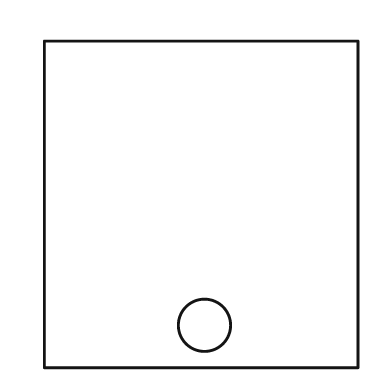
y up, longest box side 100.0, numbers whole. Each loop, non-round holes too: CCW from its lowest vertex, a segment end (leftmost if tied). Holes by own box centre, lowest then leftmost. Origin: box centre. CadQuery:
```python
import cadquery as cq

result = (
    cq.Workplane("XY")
    .moveTo(-48.0, -50.0)
    .lineTo(48.0, -50.0)
    .lineTo(48.0, 50.0)
    .lineTo(-48.0, 50.0)
    .close()
    .moveTo(1.0, -37.0)
    .circle(8.0)
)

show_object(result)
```